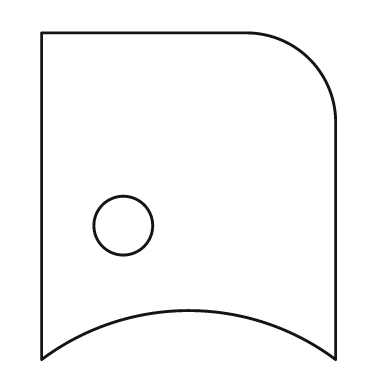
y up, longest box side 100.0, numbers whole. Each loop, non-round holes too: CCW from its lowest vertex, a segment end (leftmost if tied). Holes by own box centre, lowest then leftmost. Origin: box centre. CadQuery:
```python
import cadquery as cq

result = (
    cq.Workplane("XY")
    .moveTo(-45.0, -50.0)
    .threePointArc((0.0, -35.0), (45.0, -50.0))
    .lineTo(45.0, 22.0)
    .threePointArc((37.0, 42.0), (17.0, 50.0))
    .lineTo(-45.0, 50.0)
    .close()
    .moveTo(-20.0, -9.0)
    .circle(9.0)
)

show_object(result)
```